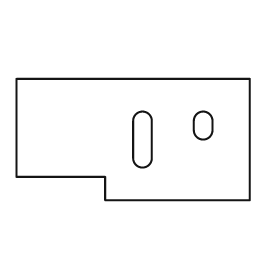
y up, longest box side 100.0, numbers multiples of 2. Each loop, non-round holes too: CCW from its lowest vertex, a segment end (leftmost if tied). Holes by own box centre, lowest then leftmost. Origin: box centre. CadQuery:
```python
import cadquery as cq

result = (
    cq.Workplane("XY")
    .moveTo(-12.0, -26.0)
    .lineTo(50.0, -26.0)
    .lineTo(50.0, 26.0)
    .lineTo(-50.0, 26.0)
    .lineTo(-50.0, -16.0)
    .lineTo(-12.0, -16.0)
    .close()
    .moveTo(0.0, -8.0)
    .threePointArc((4.0, -12.0), (8.0, -8.0))
    .lineTo(8.0, 8.0)
    .threePointArc((4.0, 12.0), (0.0, 8.0))
    .close()
    .moveTo(26.0, 4.0)
    .threePointArc((30.0, 0.0), (34.0, 4.0))
    .lineTo(34.0, 8.0)
    .threePointArc((30.0, 12.0), (26.0, 8.0))
    .close()
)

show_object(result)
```